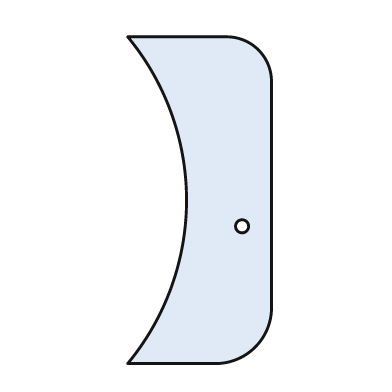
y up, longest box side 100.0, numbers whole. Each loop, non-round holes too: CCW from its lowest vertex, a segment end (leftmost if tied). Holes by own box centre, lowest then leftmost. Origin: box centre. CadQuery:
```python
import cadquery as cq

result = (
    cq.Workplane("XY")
    .moveTo(-22.0, -50.0)
    .lineTo(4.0, -50.0)
    .threePointArc((17.0, -45.0), (22.0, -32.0))
    .lineTo(22.0, 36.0)
    .threePointArc((18.0, 46.0), (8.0, 50.0))
    .lineTo(-22.0, 50.0)
    .threePointArc((-4.0, 0.0), (-22.0, -50.0))
    .close()
    .moveTo(13.0, -8.0)
    .circle(2.0)
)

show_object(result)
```